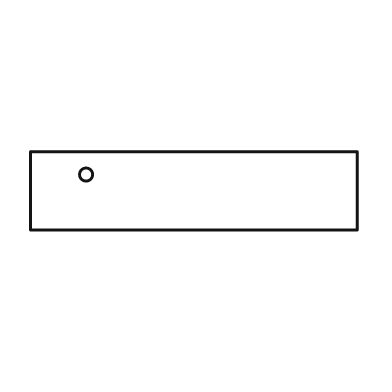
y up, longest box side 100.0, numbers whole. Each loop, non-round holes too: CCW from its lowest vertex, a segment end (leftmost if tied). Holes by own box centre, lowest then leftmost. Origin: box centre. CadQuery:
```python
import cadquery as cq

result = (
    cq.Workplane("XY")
    .moveTo(-50.0, -12.0)
    .lineTo(50.0, -12.0)
    .lineTo(50.0, 12.0)
    .lineTo(-50.0, 12.0)
    .close()
    .moveTo(-33.0, 5.0)
    .circle(2.0)
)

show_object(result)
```